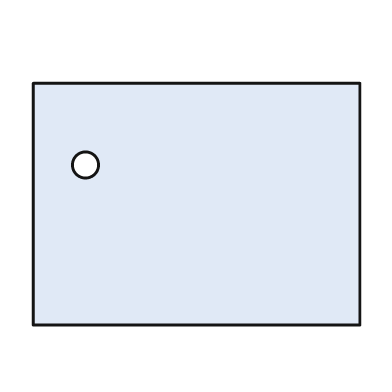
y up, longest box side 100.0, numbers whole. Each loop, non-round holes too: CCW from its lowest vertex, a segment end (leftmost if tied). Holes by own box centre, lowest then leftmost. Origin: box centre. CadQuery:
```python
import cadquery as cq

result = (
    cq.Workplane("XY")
    .moveTo(-50.0, -37.0)
    .lineTo(50.0, -37.0)
    .lineTo(50.0, 37.0)
    .lineTo(-50.0, 37.0)
    .close()
    .moveTo(-34.0, 12.0)
    .circle(4.0)
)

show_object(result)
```